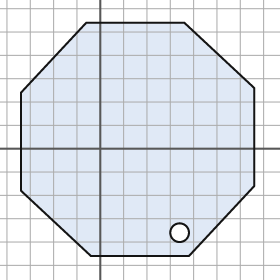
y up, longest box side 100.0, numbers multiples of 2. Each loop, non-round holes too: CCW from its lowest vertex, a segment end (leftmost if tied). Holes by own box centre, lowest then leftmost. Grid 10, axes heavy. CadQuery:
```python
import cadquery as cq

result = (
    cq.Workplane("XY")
    .moveTo(-4.0, -46.0)
    .lineTo(38.0, -46.0)
    .lineTo(66.0, -16.0)
    .lineTo(66.0, 26.0)
    .lineTo(36.0, 54.0)
    .lineTo(-6.0, 54.0)
    .lineTo(-34.0, 24.0)
    .lineTo(-34.0, -18.0)
    .close()
    .moveTo(34.0, -36.0)
    .circle(4.0)
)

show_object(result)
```